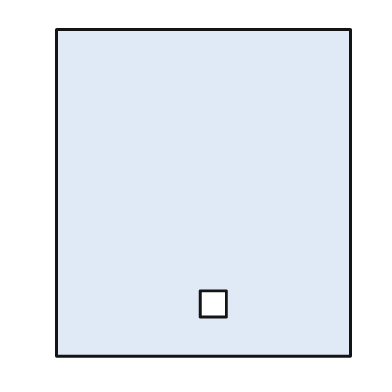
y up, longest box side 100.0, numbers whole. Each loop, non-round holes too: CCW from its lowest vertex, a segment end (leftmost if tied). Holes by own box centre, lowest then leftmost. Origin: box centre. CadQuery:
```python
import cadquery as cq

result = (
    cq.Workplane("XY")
    .moveTo(-45.0, -50.0)
    .lineTo(45.0, -50.0)
    .lineTo(45.0, 50.0)
    .lineTo(-45.0, 50.0)
    .close()
    .moveTo(-1.0, -38.0)
    .lineTo(7.0, -38.0)
    .lineTo(7.0, -30.0)
    .lineTo(-1.0, -30.0)
    .close()
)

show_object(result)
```